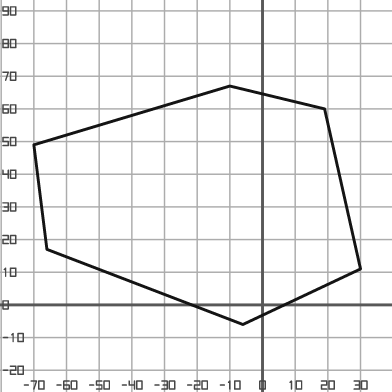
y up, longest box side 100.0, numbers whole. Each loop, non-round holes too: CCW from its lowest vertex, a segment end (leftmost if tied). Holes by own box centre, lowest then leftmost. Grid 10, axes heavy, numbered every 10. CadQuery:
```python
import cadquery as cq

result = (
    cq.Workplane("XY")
    .moveTo(-6.0, -6.0)
    .lineTo(30.0, 11.0)
    .lineTo(19.0, 60.0)
    .lineTo(-10.0, 67.0)
    .lineTo(-70.0, 49.0)
    .lineTo(-66.0, 17.0)
    .close()
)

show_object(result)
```